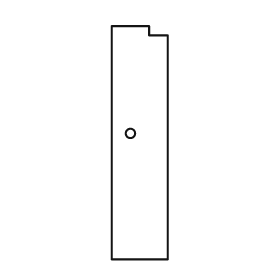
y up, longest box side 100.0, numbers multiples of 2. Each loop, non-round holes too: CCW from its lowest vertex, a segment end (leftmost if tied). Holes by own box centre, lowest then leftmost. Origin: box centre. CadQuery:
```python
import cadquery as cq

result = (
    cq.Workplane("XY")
    .moveTo(-12.0, -50.0)
    .lineTo(12.0, -50.0)
    .lineTo(12.0, 46.0)
    .lineTo(4.0, 46.0)
    .lineTo(4.0, 50.0)
    .lineTo(-12.0, 50.0)
    .close()
    .moveTo(-4.0, 4.0)
    .circle(2.0)
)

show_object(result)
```